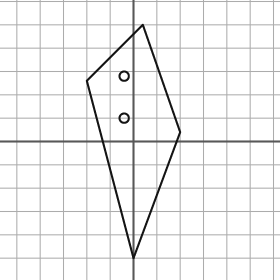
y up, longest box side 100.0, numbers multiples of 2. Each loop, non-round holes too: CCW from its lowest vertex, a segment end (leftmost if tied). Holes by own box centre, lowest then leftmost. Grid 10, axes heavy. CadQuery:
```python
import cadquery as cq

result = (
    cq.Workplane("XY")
    .moveTo(0.0, -50.0)
    .lineTo(20.0, 4.0)
    .lineTo(4.0, 50.0)
    .lineTo(-20.0, 26.0)
    .close()
    .moveTo(-4.0, 10.0)
    .circle(2.0)
    .moveTo(-4.0, 28.0)
    .circle(2.0)
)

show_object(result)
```